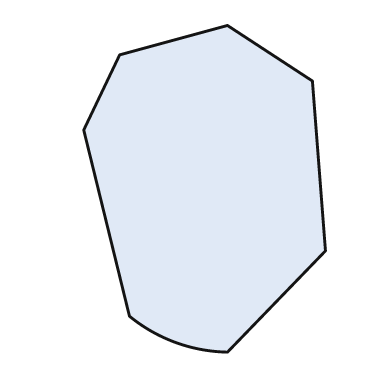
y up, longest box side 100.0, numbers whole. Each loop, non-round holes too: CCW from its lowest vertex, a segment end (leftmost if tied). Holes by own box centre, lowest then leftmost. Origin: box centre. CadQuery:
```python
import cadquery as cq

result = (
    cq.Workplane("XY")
    .moveTo(7.0, -50.0)
    .lineTo(37.0, -19.0)
    .lineTo(33.0, 33.0)
    .lineTo(7.0, 50.0)
    .lineTo(-26.0, 41.0)
    .lineTo(-37.0, 18.0)
    .lineTo(-23.0, -39.0)
    .threePointArc((-9.0, -47.0), (7.0, -50.0))
    .close()
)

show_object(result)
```